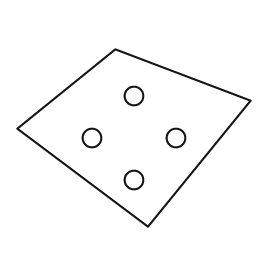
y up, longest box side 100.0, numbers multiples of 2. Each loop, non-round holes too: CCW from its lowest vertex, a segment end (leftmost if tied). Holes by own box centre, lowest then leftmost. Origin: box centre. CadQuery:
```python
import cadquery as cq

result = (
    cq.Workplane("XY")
    .moveTo(6.0, -38.0)
    .lineTo(50.0, 16.0)
    .lineTo(-8.0, 38.0)
    .lineTo(-50.0, 4.0)
    .close()
    .moveTo(0.0, -18.0)
    .circle(4.0)
    .moveTo(-18.0, 0.0)
    .circle(4.0)
    .moveTo(18.0, 0.0)
    .circle(4.0)
    .moveTo(0.0, 18.0)
    .circle(4.0)
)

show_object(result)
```